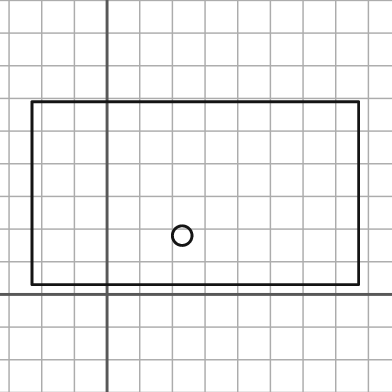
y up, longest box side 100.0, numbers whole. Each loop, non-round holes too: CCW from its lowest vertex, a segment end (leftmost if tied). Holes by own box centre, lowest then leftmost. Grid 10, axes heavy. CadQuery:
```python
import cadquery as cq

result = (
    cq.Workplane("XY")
    .moveTo(-23.0, 3.0)
    .lineTo(77.0, 3.0)
    .lineTo(77.0, 59.0)
    .lineTo(-23.0, 59.0)
    .close()
    .moveTo(23.0, 18.0)
    .circle(3.0)
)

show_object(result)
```